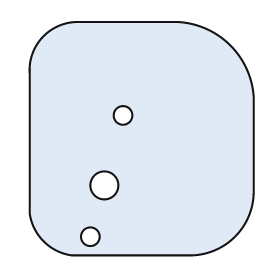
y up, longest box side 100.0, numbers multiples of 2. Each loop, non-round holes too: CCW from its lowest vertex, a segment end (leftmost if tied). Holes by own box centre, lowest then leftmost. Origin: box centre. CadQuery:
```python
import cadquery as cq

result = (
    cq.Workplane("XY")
    .moveTo(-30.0, -50.0)
    .lineTo(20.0, -50.0)
    .threePointArc((40.0, -42.0), (48.0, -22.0))
    .lineTo(48.0, 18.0)
    .threePointArc((38.0, 40.0), (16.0, 50.0))
    .lineTo(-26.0, 50.0)
    .threePointArc((-42.0, 44.0), (-48.0, 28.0))
    .lineTo(-48.0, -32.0)
    .threePointArc((-42.0, -44.0), (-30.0, -50.0))
    .close()
    .moveTo(-22.0, -42.0)
    .circle(4.0)
    .moveTo(-16.0, -20.0)
    .circle(6.0)
    .moveTo(-8.0, 10.0)
    .circle(4.0)
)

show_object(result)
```